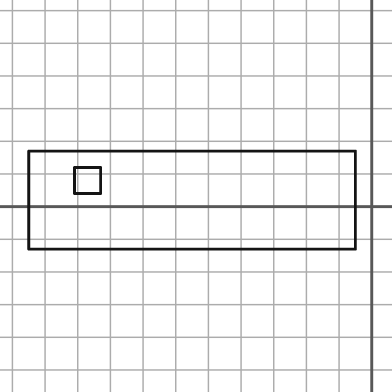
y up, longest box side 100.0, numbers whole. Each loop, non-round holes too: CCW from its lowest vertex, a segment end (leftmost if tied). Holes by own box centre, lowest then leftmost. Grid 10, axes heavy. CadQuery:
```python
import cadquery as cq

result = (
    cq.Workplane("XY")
    .moveTo(-105.0, -13.0)
    .lineTo(-5.0, -13.0)
    .lineTo(-5.0, 17.0)
    .lineTo(-105.0, 17.0)
    .close()
    .moveTo(-91.0, 4.0)
    .lineTo(-83.0, 4.0)
    .lineTo(-83.0, 12.0)
    .lineTo(-91.0, 12.0)
    .close()
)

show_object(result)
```